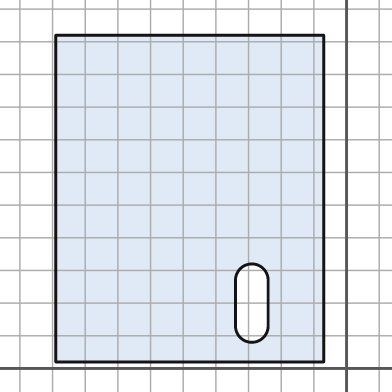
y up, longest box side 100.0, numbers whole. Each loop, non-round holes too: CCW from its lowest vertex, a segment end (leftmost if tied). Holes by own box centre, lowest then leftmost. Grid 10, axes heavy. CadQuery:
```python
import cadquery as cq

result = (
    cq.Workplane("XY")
    .moveTo(-89.0, 2.0)
    .lineTo(-7.0, 2.0)
    .lineTo(-7.0, 102.0)
    .lineTo(-89.0, 102.0)
    .close()
    .moveTo(-34.0, 13.0)
    .threePointArc((-29.0, 8.0), (-24.0, 13.0))
    .lineTo(-24.0, 27.0)
    .threePointArc((-29.0, 32.0), (-34.0, 27.0))
    .close()
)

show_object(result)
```